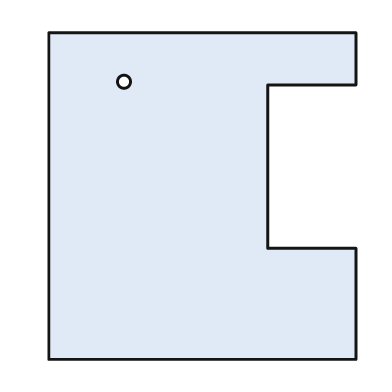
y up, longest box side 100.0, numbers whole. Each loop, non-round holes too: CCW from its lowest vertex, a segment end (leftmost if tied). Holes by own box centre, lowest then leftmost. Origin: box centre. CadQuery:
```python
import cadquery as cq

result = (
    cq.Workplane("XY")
    .moveTo(-47.0, -50.0)
    .lineTo(47.0, -50.0)
    .lineTo(47.0, -16.0)
    .lineTo(20.0, -16.0)
    .lineTo(20.0, 34.0)
    .lineTo(47.0, 34.0)
    .lineTo(47.0, 50.0)
    .lineTo(-47.0, 50.0)
    .close()
    .moveTo(-24.0, 35.0)
    .circle(2.0)
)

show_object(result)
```